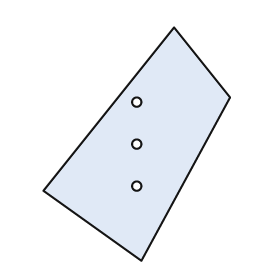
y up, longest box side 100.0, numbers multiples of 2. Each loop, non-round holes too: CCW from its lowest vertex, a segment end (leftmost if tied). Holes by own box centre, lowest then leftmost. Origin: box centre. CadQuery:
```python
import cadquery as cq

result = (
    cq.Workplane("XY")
    .moveTo(2.0, -50.0)
    .lineTo(40.0, 20.0)
    .lineTo(16.0, 50.0)
    .lineTo(-40.0, -20.0)
    .close()
    .moveTo(0.0, -18.0)
    .circle(2.0)
    .moveTo(0.0, 0.0)
    .circle(2.0)
    .moveTo(0.0, 18.0)
    .circle(2.0)
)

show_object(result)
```